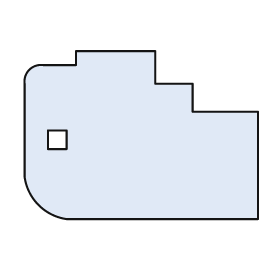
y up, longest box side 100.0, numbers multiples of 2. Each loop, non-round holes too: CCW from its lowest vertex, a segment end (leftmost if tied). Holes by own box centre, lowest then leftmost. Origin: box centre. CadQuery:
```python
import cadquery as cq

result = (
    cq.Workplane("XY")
    .moveTo(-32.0, -36.0)
    .lineTo(50.0, -36.0)
    .lineTo(50.0, 10.0)
    .lineTo(22.0, 10.0)
    .lineTo(22.0, 22.0)
    .lineTo(6.0, 22.0)
    .lineTo(6.0, 36.0)
    .lineTo(-28.0, 36.0)
    .lineTo(-28.0, 30.0)
    .lineTo(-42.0, 30.0)
    .threePointArc((-48.0, 28.0), (-50.0, 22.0))
    .lineTo(-50.0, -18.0)
    .threePointArc((-44.0, -30.0), (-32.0, -36.0))
    .close()
    .moveTo(-40.0, -6.0)
    .lineTo(-32.0, -6.0)
    .lineTo(-32.0, 2.0)
    .lineTo(-40.0, 2.0)
    .close()
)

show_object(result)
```